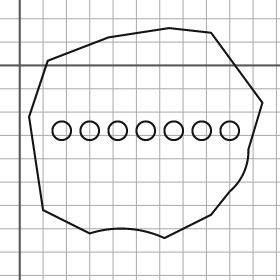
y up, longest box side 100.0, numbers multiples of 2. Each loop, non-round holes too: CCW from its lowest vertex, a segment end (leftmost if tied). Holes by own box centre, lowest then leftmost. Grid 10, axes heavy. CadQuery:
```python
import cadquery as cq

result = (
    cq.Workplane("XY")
    .moveTo(62.0, -74.0)
    .lineTo(82.0, -64.0)
    .lineTo(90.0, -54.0)
    .threePointArc((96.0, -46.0), (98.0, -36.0))
    .lineTo(104.0, -16.0)
    .lineTo(82.0, 14.0)
    .lineTo(64.0, 16.0)
    .lineTo(38.0, 12.0)
    .lineTo(12.0, 2.0)
    .lineTo(4.0, -22.0)
    .lineTo(10.0, -62.0)
    .lineTo(30.0, -72.0)
    .threePointArc((46.0, -70.0), (62.0, -74.0))
    .close()
    .moveTo(18.0, -28.0)
    .circle(4.0)
    .moveTo(30.0, -28.0)
    .circle(4.0)
    .moveTo(42.0, -28.0)
    .circle(4.0)
    .moveTo(54.0, -28.0)
    .circle(4.0)
    .moveTo(66.0, -28.0)
    .circle(4.0)
    .moveTo(78.0, -28.0)
    .circle(4.0)
    .moveTo(90.0, -28.0)
    .circle(4.0)
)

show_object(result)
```